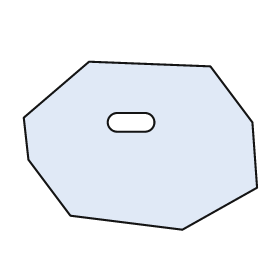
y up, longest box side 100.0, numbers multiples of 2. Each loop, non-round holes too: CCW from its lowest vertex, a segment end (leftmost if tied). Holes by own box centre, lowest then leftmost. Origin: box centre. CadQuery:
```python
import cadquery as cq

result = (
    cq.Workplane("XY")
    .moveTo(18.0, -36.0)
    .lineTo(50.0, -18.0)
    .lineTo(48.0, 10.0)
    .lineTo(30.0, 34.0)
    .lineTo(-22.0, 36.0)
    .lineTo(-50.0, 12.0)
    .lineTo(-48.0, -6.0)
    .lineTo(-30.0, -30.0)
    .close()
    .moveTo(-10.0, 6.0)
    .lineTo(2.0, 6.0)
    .threePointArc((6.0, 10.0), (2.0, 14.0))
    .lineTo(-10.0, 14.0)
    .threePointArc((-14.0, 10.0), (-10.0, 6.0))
    .close()
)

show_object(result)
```